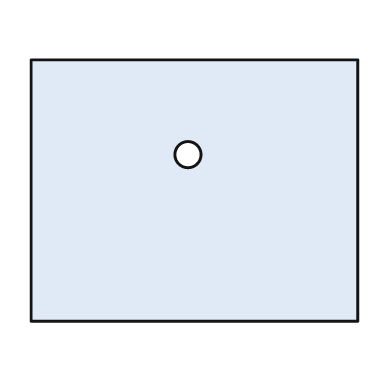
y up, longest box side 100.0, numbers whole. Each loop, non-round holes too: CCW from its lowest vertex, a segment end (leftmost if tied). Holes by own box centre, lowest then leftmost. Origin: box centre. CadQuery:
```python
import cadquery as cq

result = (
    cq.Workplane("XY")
    .moveTo(-50.0, -40.0)
    .lineTo(50.0, -40.0)
    .lineTo(50.0, 40.0)
    .lineTo(-50.0, 40.0)
    .close()
    .moveTo(-2.0, 11.0)
    .circle(4.0)
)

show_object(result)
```